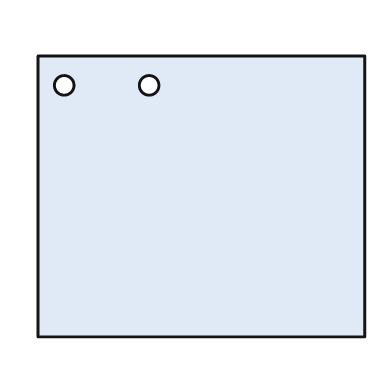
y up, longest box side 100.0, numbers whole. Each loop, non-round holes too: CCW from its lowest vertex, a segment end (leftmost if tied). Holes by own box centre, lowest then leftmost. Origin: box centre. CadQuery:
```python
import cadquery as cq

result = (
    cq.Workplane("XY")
    .moveTo(-50.0, -43.0)
    .lineTo(50.0, -43.0)
    .lineTo(50.0, 43.0)
    .lineTo(-50.0, 43.0)
    .close()
    .moveTo(-42.0, 34.0)
    .circle(3.0)
    .moveTo(-16.0, 34.0)
    .circle(3.0)
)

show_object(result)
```